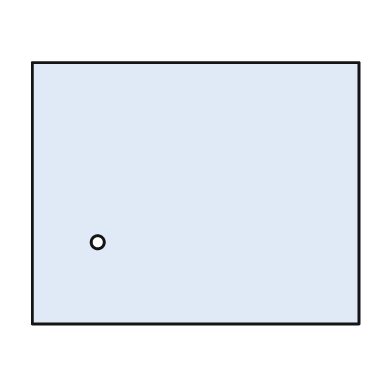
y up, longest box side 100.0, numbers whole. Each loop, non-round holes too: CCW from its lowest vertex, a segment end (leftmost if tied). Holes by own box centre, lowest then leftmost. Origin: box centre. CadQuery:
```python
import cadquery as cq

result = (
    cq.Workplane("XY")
    .moveTo(-50.0, -40.0)
    .lineTo(50.0, -40.0)
    .lineTo(50.0, 40.0)
    .lineTo(-50.0, 40.0)
    .close()
    .moveTo(-30.0, -15.0)
    .circle(2.0)
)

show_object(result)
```